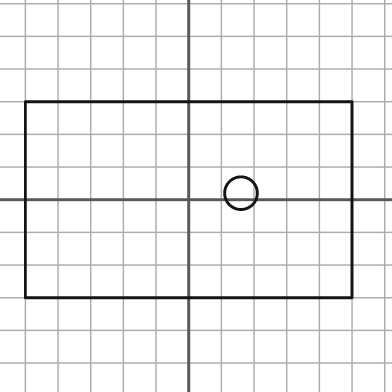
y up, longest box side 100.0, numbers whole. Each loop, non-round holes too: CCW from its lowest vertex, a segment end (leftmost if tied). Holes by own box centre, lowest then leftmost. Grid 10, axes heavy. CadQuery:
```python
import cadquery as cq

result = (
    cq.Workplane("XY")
    .moveTo(-50.0, -30.0)
    .lineTo(50.0, -30.0)
    .lineTo(50.0, 30.0)
    .lineTo(-50.0, 30.0)
    .close()
    .moveTo(16.0, 2.0)
    .circle(5.0)
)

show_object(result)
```